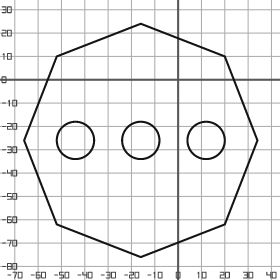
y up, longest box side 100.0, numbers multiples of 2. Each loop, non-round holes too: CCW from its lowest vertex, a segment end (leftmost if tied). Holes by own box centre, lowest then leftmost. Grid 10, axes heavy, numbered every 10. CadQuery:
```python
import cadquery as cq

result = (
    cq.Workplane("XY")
    .moveTo(-16.0, -76.0)
    .lineTo(20.0, -62.0)
    .lineTo(34.0, -26.0)
    .lineTo(20.0, 10.0)
    .lineTo(-16.0, 24.0)
    .lineTo(-52.0, 10.0)
    .lineTo(-66.0, -26.0)
    .lineTo(-52.0, -62.0)
    .close()
    .moveTo(-44.0, -26.0)
    .circle(8.0)
    .moveTo(-16.0, -26.0)
    .circle(8.0)
    .moveTo(12.0, -26.0)
    .circle(8.0)
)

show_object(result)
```